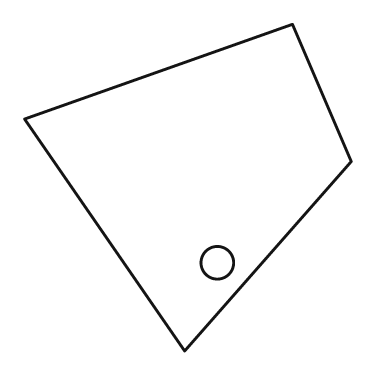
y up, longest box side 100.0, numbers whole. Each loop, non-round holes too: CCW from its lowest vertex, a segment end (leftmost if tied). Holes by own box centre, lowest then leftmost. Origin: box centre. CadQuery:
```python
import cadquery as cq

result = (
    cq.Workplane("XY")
    .moveTo(-1.0, -50.0)
    .lineTo(50.0, 8.0)
    .lineTo(32.0, 50.0)
    .lineTo(-50.0, 21.0)
    .close()
    .moveTo(9.0, -23.0)
    .circle(5.0)
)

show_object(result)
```